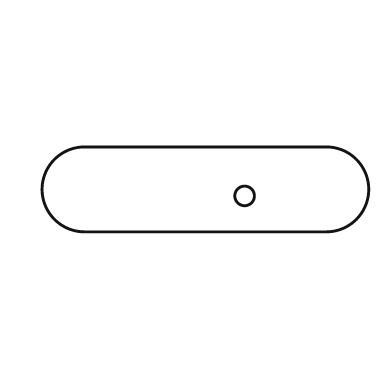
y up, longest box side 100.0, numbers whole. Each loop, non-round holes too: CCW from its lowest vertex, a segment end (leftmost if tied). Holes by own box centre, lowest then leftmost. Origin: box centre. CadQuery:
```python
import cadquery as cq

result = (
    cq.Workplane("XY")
    .moveTo(-37.0, -13.0)
    .lineTo(37.0, -13.0)
    .threePointArc((50.0, 0.0), (37.0, 13.0))
    .lineTo(-37.0, 13.0)
    .threePointArc((-50.0, 0.0), (-37.0, -13.0))
    .close()
    .moveTo(12.0, -2.0)
    .circle(3.0)
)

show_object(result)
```